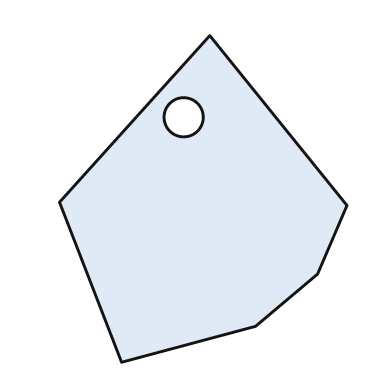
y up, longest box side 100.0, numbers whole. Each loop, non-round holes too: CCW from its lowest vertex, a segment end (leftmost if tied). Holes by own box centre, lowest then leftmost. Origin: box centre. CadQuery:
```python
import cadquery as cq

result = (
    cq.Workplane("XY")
    .moveTo(-25.0, -50.0)
    .lineTo(16.0, -39.0)
    .lineTo(35.0, -23.0)
    .lineTo(44.0, -2.0)
    .lineTo(2.0, 50.0)
    .lineTo(-44.0, -1.0)
    .close()
    .moveTo(-6.0, 25.0)
    .circle(6.0)
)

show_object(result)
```